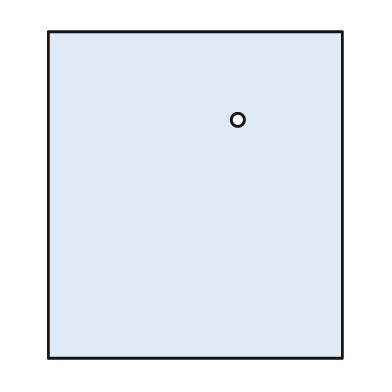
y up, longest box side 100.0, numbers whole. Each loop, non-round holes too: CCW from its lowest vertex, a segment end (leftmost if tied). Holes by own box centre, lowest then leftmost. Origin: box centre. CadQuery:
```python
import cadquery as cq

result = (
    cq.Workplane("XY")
    .moveTo(-45.0, -50.0)
    .lineTo(45.0, -50.0)
    .lineTo(45.0, 50.0)
    .lineTo(-45.0, 50.0)
    .close()
    .moveTo(13.0, 23.0)
    .circle(2.0)
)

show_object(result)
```